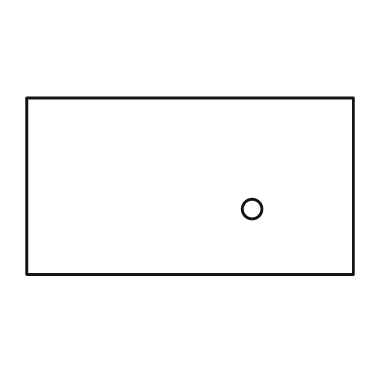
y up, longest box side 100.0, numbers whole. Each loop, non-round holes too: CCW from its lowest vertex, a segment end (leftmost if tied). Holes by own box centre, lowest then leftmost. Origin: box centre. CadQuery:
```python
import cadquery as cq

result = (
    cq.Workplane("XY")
    .moveTo(-50.0, -27.0)
    .lineTo(50.0, -27.0)
    .lineTo(50.0, 27.0)
    .lineTo(-50.0, 27.0)
    .close()
    .moveTo(19.0, -7.0)
    .circle(3.0)
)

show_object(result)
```